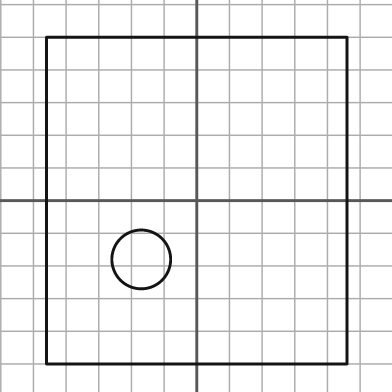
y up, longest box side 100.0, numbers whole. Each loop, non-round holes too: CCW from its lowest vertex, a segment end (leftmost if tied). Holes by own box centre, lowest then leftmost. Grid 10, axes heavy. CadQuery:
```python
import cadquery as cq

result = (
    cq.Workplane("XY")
    .moveTo(-46.0, -50.0)
    .lineTo(46.0, -50.0)
    .lineTo(46.0, 50.0)
    .lineTo(-46.0, 50.0)
    .close()
    .moveTo(-17.0, -18.0)
    .circle(9.0)
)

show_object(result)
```